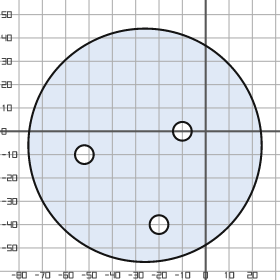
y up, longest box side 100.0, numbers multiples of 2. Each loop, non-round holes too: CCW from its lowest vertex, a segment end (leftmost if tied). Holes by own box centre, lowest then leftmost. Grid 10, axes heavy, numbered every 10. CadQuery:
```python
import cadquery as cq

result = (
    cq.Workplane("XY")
    .moveTo(-26.0, -6.0)
    .circle(50.0)
    .moveTo(-20.0, -40.0)
    .circle(4.0)
    .moveTo(-52.0, -10.0)
    .circle(4.0)
    .moveTo(-10.0, 0.0)
    .circle(4.0)
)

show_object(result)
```